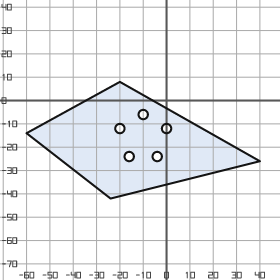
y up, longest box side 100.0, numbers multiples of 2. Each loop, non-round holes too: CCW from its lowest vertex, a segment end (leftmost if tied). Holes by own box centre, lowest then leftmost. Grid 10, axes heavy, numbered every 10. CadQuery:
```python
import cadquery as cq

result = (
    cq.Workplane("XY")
    .moveTo(-24.0, -42.0)
    .lineTo(40.0, -26.0)
    .lineTo(-20.0, 8.0)
    .lineTo(-60.0, -14.0)
    .close()
    .moveTo(-16.0, -24.0)
    .circle(2.0)
    .moveTo(-4.0, -24.0)
    .circle(2.0)
    .moveTo(-20.0, -12.0)
    .circle(2.0)
    .moveTo(0.0, -12.0)
    .circle(2.0)
    .moveTo(-10.0, -6.0)
    .circle(2.0)
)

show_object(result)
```